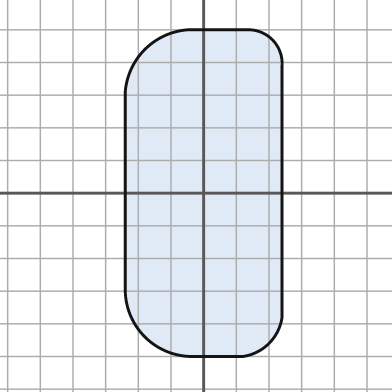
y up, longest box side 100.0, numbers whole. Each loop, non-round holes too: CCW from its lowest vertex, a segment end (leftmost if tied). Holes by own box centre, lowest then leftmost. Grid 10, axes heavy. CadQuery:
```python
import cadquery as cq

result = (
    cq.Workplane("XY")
    .moveTo(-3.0, -50.0)
    .lineTo(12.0, -50.0)
    .threePointArc((20.0, -46.0), (24.0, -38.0))
    .lineTo(24.0, 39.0)
    .threePointArc((21.0, 47.0), (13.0, 50.0))
    .lineTo(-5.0, 50.0)
    .threePointArc((-18.0, 44.0), (-24.0, 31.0))
    .lineTo(-24.0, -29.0)
    .threePointArc((-18.0, -44.0), (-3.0, -50.0))
    .close()
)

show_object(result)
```